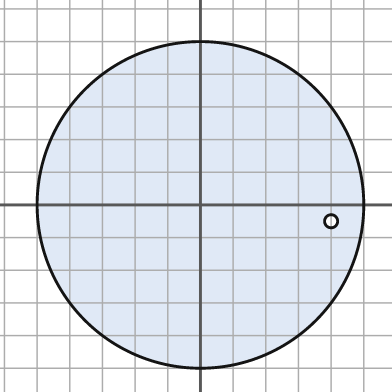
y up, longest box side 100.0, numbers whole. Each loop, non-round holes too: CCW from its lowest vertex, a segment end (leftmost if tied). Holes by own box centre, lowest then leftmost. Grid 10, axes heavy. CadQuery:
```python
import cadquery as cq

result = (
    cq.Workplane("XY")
    .moveTo(0.0, 0.0)
    .circle(50.0)
    .moveTo(40.0, -5.0)
    .circle(2.0)
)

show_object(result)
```